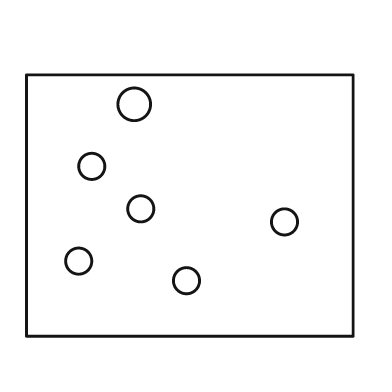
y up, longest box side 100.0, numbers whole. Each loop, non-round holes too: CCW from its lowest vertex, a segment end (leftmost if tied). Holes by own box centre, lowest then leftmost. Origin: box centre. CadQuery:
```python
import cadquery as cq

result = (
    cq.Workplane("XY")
    .moveTo(-50.0, -40.0)
    .lineTo(50.0, -40.0)
    .lineTo(50.0, 40.0)
    .lineTo(-50.0, 40.0)
    .close()
    .moveTo(-1.0, -23.0)
    .circle(4.0)
    .moveTo(-34.0, -17.0)
    .circle(4.0)
    .moveTo(29.0, -5.0)
    .circle(4.0)
    .moveTo(-15.0, -1.0)
    .circle(4.0)
    .moveTo(-30.0, 12.0)
    .circle(4.0)
    .moveTo(-17.0, 31.0)
    .circle(5.0)
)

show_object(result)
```